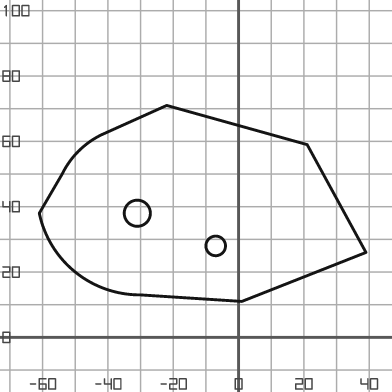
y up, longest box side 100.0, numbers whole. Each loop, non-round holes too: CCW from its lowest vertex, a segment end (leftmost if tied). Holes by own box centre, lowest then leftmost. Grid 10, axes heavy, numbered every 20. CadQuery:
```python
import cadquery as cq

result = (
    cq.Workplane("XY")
    .moveTo(1.0, 11.0)
    .lineTo(39.0, 26.0)
    .lineTo(21.0, 59.0)
    .lineTo(-22.0, 71.0)
    .lineTo(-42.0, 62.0)
    .threePointArc((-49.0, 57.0), (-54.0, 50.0))
    .lineTo(-61.0, 38.0)
    .threePointArc((-50.0, 20.0), (-30.0, 13.0))
    .close()
    .moveTo(-7.0, 28.0)
    .circle(3.0)
    .moveTo(-31.0, 38.0)
    .circle(4.0)
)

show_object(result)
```